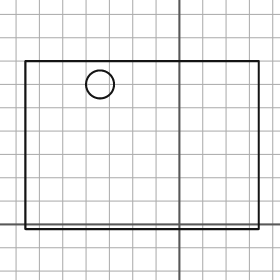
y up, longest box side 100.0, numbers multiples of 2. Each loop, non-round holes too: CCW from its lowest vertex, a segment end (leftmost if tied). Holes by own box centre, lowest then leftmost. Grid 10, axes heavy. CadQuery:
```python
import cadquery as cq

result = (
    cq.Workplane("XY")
    .moveTo(-66.0, -2.0)
    .lineTo(34.0, -2.0)
    .lineTo(34.0, 70.0)
    .lineTo(-66.0, 70.0)
    .close()
    .moveTo(-34.0, 60.0)
    .circle(6.0)
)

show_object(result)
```